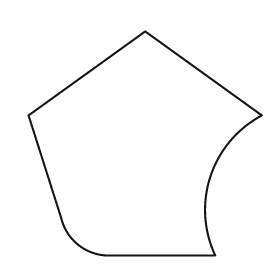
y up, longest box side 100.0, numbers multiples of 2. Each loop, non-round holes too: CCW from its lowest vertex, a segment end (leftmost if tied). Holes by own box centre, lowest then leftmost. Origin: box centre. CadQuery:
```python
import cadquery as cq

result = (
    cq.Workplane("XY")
    .moveTo(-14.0, -48.0)
    .lineTo(30.0, -48.0)
    .threePointArc((28.0, -14.0), (50.0, 12.0))
    .lineTo(0.0, 48.0)
    .lineTo(-50.0, 12.0)
    .lineTo(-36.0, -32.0)
    .threePointArc((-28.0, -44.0), (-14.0, -48.0))
    .close()
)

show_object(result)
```